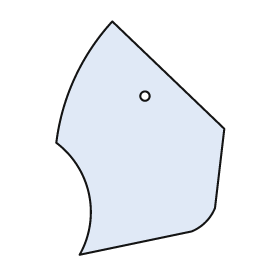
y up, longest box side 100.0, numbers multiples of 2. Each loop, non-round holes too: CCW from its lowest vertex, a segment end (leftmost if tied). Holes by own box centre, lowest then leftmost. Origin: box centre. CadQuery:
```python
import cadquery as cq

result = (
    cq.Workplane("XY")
    .moveTo(-26.0, -50.0)
    .lineTo(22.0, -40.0)
    .threePointArc((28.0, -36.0), (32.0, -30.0))
    .lineTo(36.0, 4.0)
    .lineTo(-12.0, 50.0)
    .threePointArc((-28.0, 26.0), (-36.0, -2.0))
    .threePointArc((-22.0, -24.0), (-26.0, -50.0))
    .close()
    .moveTo(2.0, 18.0)
    .circle(2.0)
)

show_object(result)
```